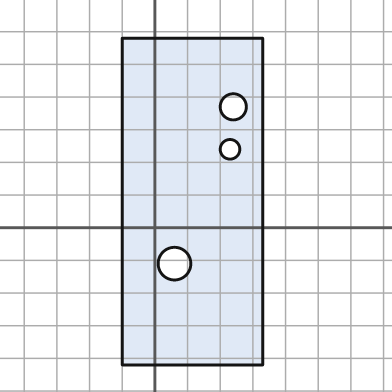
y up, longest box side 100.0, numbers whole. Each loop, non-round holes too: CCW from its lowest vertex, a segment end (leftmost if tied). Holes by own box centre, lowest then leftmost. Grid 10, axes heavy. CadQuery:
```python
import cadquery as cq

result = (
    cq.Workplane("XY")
    .moveTo(-10.0, -42.0)
    .lineTo(33.0, -42.0)
    .lineTo(33.0, 58.0)
    .lineTo(-10.0, 58.0)
    .close()
    .moveTo(6.0, -11.0)
    .circle(5.0)
    .moveTo(23.0, 24.0)
    .circle(3.0)
    .moveTo(24.0, 37.0)
    .circle(4.0)
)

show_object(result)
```